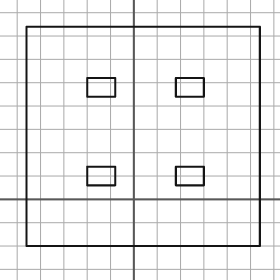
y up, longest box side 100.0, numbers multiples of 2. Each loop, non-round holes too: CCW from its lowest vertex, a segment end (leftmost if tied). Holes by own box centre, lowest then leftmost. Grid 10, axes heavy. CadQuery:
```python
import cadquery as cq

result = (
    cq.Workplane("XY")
    .moveTo(-46.0, -20.0)
    .lineTo(54.0, -20.0)
    .lineTo(54.0, 74.0)
    .lineTo(-46.0, 74.0)
    .close()
    .moveTo(-20.0, 6.0)
    .lineTo(-8.0, 6.0)
    .lineTo(-8.0, 14.0)
    .lineTo(-20.0, 14.0)
    .close()
    .moveTo(18.0, 6.0)
    .lineTo(30.0, 6.0)
    .lineTo(30.0, 14.0)
    .lineTo(18.0, 14.0)
    .close()
    .moveTo(-20.0, 44.0)
    .lineTo(-8.0, 44.0)
    .lineTo(-8.0, 52.0)
    .lineTo(-20.0, 52.0)
    .close()
    .moveTo(18.0, 44.0)
    .lineTo(30.0, 44.0)
    .lineTo(30.0, 52.0)
    .lineTo(18.0, 52.0)
    .close()
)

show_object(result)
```